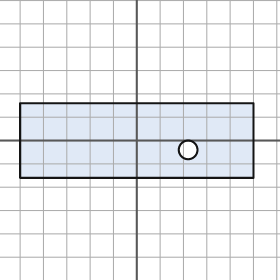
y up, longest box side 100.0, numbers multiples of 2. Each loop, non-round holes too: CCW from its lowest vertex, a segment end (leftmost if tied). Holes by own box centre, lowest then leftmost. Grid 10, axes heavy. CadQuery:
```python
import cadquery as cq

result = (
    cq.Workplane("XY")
    .moveTo(-50.0, -16.0)
    .lineTo(50.0, -16.0)
    .lineTo(50.0, 16.0)
    .lineTo(-50.0, 16.0)
    .close()
    .moveTo(22.0, -4.0)
    .circle(4.0)
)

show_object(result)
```